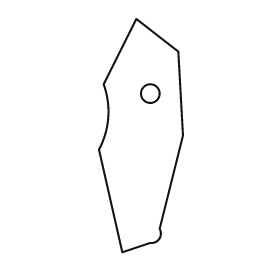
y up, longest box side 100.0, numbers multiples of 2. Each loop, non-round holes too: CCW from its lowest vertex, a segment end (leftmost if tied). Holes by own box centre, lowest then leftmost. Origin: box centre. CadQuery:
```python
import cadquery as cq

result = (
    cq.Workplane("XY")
    .moveTo(-8.0, -50.0)
    .lineTo(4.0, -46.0)
    .threePointArc((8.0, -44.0), (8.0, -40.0))
    .lineTo(18.0, 0.0)
    .lineTo(16.0, 36.0)
    .lineTo(-2.0, 50.0)
    .lineTo(-16.0, 22.0)
    .threePointArc((-14.0, 8.0), (-18.0, -6.0))
    .close()
    .moveTo(4.0, 18.0)
    .circle(4.0)
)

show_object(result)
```